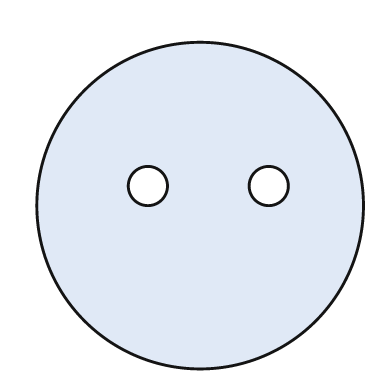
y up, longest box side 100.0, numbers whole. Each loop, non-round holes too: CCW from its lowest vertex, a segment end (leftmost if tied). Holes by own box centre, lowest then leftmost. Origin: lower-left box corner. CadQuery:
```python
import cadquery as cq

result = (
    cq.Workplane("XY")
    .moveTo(50.0, 50.0)
    .circle(50.0)
    .moveTo(34.0, 56.0)
    .circle(6.0)
    .moveTo(71.0, 56.0)
    .circle(6.0)
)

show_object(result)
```